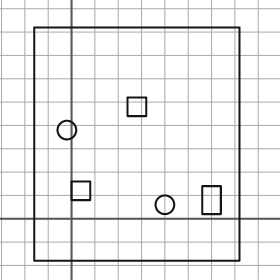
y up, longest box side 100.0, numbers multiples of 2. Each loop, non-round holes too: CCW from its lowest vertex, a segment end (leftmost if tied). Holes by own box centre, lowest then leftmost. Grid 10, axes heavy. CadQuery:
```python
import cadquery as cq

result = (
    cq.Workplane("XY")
    .moveTo(-16.0, -18.0)
    .lineTo(72.0, -18.0)
    .lineTo(72.0, 82.0)
    .lineTo(-16.0, 82.0)
    .close()
    .moveTo(40.0, 6.0)
    .circle(4.0)
    .moveTo(56.0, 2.0)
    .lineTo(64.0, 2.0)
    .lineTo(64.0, 14.0)
    .lineTo(56.0, 14.0)
    .close()
    .moveTo(0.0, 8.0)
    .lineTo(8.0, 8.0)
    .lineTo(8.0, 16.0)
    .lineTo(0.0, 16.0)
    .close()
    .moveTo(-2.0, 38.0)
    .circle(4.0)
    .moveTo(24.0, 44.0)
    .lineTo(32.0, 44.0)
    .lineTo(32.0, 52.0)
    .lineTo(24.0, 52.0)
    .close()
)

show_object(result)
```